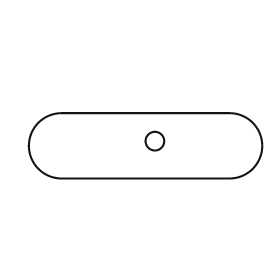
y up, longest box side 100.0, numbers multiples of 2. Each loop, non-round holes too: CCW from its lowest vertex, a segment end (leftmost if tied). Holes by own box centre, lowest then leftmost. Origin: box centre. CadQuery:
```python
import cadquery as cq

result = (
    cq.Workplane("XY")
    .moveTo(-36.0, -14.0)
    .lineTo(36.0, -14.0)
    .threePointArc((50.0, 0.0), (36.0, 14.0))
    .lineTo(-36.0, 14.0)
    .threePointArc((-50.0, 0.0), (-36.0, -14.0))
    .close()
    .moveTo(4.0, 2.0)
    .circle(4.0)
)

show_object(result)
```